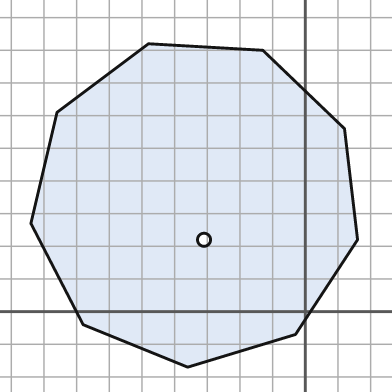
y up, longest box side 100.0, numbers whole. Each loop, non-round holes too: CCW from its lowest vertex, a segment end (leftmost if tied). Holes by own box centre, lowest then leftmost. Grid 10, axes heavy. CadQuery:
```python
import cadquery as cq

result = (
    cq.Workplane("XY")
    .moveTo(-36.0, -17.0)
    .lineTo(-3.0, -7.0)
    .lineTo(16.0, 22.0)
    .lineTo(12.0, 56.0)
    .lineTo(-13.0, 80.0)
    .lineTo(-48.0, 82.0)
    .lineTo(-76.0, 61.0)
    .lineTo(-84.0, 27.0)
    .lineTo(-68.0, -4.0)
    .close()
    .moveTo(-31.0, 22.0)
    .circle(2.0)
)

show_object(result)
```